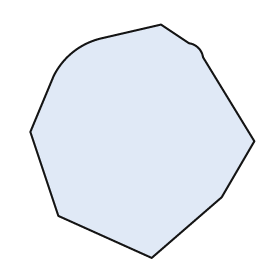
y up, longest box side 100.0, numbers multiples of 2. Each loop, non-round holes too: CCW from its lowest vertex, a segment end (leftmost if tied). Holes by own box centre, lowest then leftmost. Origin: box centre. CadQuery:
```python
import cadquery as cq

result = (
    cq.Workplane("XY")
    .moveTo(4.0, -50.0)
    .lineTo(34.0, -24.0)
    .lineTo(48.0, 0.0)
    .lineTo(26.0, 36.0)
    .threePointArc((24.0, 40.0), (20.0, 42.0))
    .lineTo(8.0, 50.0)
    .lineTo(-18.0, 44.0)
    .threePointArc((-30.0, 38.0), (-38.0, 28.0))
    .lineTo(-48.0, 4.0)
    .lineTo(-36.0, -32.0)
    .close()
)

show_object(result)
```